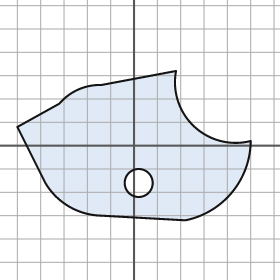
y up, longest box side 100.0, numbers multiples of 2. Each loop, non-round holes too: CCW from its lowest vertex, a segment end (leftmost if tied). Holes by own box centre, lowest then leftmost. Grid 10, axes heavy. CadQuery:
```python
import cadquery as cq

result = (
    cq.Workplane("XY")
    .moveTo(22.0, -32.0)
    .threePointArc((42.0, -20.0), (50.0, 2.0))
    .threePointArc((26.0, 8.0), (18.0, 32.0))
    .lineTo(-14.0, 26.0)
    .threePointArc((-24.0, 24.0), (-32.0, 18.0))
    .lineTo(-50.0, 8.0)
    .lineTo(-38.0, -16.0)
    .threePointArc((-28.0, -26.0), (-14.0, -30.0))
    .close()
    .moveTo(2.0, -16.0)
    .circle(6.0)
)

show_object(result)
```